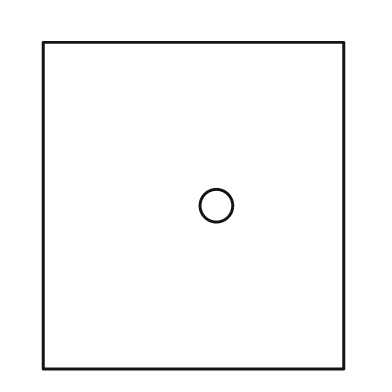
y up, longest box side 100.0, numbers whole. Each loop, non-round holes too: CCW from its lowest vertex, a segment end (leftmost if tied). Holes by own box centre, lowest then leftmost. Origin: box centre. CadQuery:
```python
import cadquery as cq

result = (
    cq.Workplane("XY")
    .moveTo(-46.0, -50.0)
    .lineTo(46.0, -50.0)
    .lineTo(46.0, 50.0)
    .lineTo(-46.0, 50.0)
    .close()
    .moveTo(7.0, 0.0)
    .circle(5.0)
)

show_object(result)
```